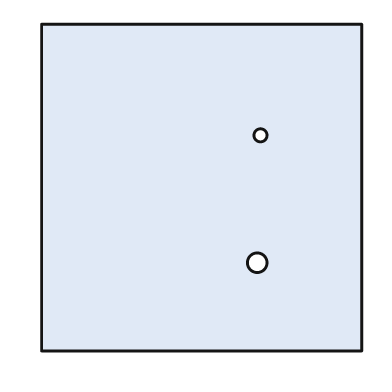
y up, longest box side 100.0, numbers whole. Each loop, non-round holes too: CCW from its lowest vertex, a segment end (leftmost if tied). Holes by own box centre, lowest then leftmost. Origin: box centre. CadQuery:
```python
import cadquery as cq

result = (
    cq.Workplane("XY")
    .moveTo(-49.0, -50.0)
    .lineTo(49.0, -50.0)
    .lineTo(49.0, 50.0)
    .lineTo(-49.0, 50.0)
    .close()
    .moveTo(17.0, -23.0)
    .circle(3.0)
    .moveTo(18.0, 16.0)
    .circle(2.0)
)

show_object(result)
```